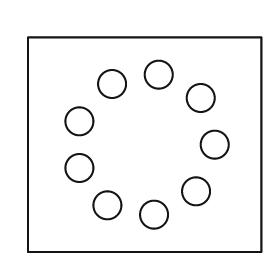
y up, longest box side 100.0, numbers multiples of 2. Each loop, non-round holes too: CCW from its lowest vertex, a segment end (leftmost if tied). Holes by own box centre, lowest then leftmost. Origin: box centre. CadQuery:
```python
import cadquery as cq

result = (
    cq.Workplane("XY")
    .moveTo(-50.0, -46.0)
    .lineTo(50.0, -46.0)
    .lineTo(50.0, 46.0)
    .lineTo(-50.0, 46.0)
    .close()
    .moveTo(4.0, -30.0)
    .circle(6.0)
    .moveTo(-16.0, -26.0)
    .circle(6.0)
    .moveTo(22.0, -20.0)
    .circle(6.0)
    .moveTo(-28.0, -10.0)
    .circle(6.0)
    .moveTo(30.0, 0.0)
    .circle(6.0)
    .moveTo(-28.0, 10.0)
    .circle(6.0)
    .moveTo(24.0, 20.0)
    .circle(6.0)
    .moveTo(-14.0, 26.0)
    .circle(6.0)
    .moveTo(6.0, 30.0)
    .circle(6.0)
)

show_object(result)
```